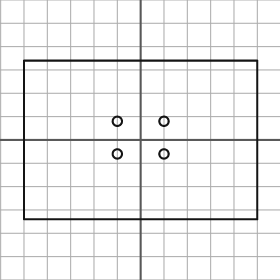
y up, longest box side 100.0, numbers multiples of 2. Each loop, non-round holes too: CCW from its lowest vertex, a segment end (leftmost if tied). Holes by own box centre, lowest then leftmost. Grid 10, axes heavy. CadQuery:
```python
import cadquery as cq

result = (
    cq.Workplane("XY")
    .moveTo(-50.0, -34.0)
    .lineTo(50.0, -34.0)
    .lineTo(50.0, 34.0)
    .lineTo(-50.0, 34.0)
    .close()
    .moveTo(-10.0, -6.0)
    .circle(2.0)
    .moveTo(10.0, -6.0)
    .circle(2.0)
    .moveTo(-10.0, 8.0)
    .circle(2.0)
    .moveTo(10.0, 8.0)
    .circle(2.0)
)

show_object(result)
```